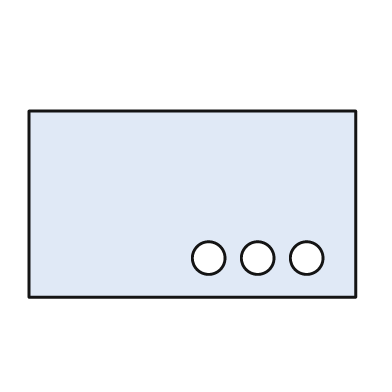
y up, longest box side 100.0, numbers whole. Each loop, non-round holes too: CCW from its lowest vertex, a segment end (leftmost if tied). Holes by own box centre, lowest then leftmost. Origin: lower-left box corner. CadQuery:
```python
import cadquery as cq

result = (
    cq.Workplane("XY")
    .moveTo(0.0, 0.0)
    .lineTo(100.0, 0.0)
    .lineTo(100.0, 57.0)
    .lineTo(0.0, 57.0)
    .close()
    .moveTo(55.0, 12.0)
    .circle(5.0)
    .moveTo(70.0, 12.0)
    .circle(5.0)
    .moveTo(85.0, 12.0)
    .circle(5.0)
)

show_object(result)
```